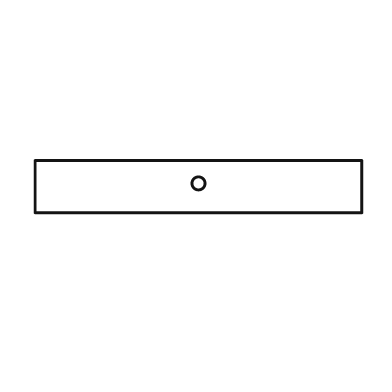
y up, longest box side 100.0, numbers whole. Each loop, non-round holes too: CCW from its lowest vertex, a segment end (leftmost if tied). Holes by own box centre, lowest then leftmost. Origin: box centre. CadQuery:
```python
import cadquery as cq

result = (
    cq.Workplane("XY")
    .moveTo(-50.0, -8.0)
    .lineTo(50.0, -8.0)
    .lineTo(50.0, 8.0)
    .lineTo(-50.0, 8.0)
    .close()
    .moveTo(0.0, 1.0)
    .circle(2.0)
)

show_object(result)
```